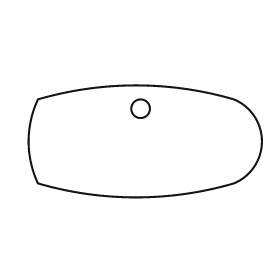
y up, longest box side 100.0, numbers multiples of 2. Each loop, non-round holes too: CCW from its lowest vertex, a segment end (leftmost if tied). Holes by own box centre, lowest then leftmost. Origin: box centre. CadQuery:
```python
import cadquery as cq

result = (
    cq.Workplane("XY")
    .moveTo(-46.0, -18.0)
    .threePointArc((-4.0, -24.0), (38.0, -18.0))
    .threePointArc((50.0, 0.0), (38.0, 18.0))
    .threePointArc((-4.0, 24.0), (-46.0, 18.0))
    .threePointArc((-50.0, 0.0), (-46.0, -18.0))
    .close()
    .moveTo(-2.0, 14.0)
    .circle(4.0)
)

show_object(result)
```